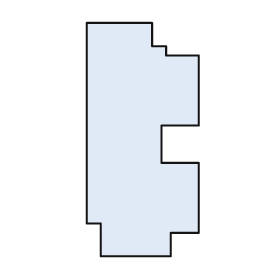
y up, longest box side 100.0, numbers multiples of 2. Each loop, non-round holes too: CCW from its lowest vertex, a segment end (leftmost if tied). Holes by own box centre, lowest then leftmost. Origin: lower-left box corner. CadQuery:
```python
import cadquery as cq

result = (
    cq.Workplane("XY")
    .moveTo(6.0, 0.0)
    .lineTo(36.0, 0.0)
    .lineTo(36.0, 10.0)
    .lineTo(48.0, 10.0)
    .lineTo(48.0, 40.0)
    .lineTo(32.0, 40.0)
    .lineTo(32.0, 56.0)
    .lineTo(48.0, 56.0)
    .lineTo(48.0, 86.0)
    .lineTo(34.0, 86.0)
    .lineTo(34.0, 90.0)
    .lineTo(28.0, 90.0)
    .lineTo(28.0, 100.0)
    .lineTo(0.0, 100.0)
    .lineTo(0.0, 14.0)
    .lineTo(6.0, 14.0)
    .close()
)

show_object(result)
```